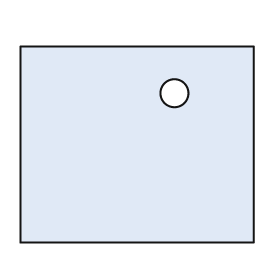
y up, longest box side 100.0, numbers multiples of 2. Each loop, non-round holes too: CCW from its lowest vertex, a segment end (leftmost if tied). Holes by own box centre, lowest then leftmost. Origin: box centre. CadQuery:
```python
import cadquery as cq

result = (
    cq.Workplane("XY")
    .moveTo(-50.0, -42.0)
    .lineTo(50.0, -42.0)
    .lineTo(50.0, 42.0)
    .lineTo(-50.0, 42.0)
    .close()
    .moveTo(16.0, 22.0)
    .circle(6.0)
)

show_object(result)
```